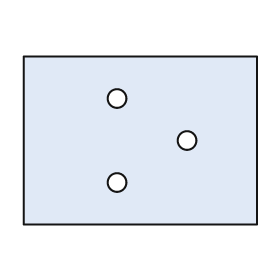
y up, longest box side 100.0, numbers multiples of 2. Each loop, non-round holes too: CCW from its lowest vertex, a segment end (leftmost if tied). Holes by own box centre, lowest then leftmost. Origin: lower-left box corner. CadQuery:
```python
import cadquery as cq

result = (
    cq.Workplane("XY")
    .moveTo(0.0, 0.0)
    .lineTo(100.0, 0.0)
    .lineTo(100.0, 72.0)
    .lineTo(0.0, 72.0)
    .close()
    .moveTo(40.0, 18.0)
    .circle(4.0)
    .moveTo(70.0, 36.0)
    .circle(4.0)
    .moveTo(40.0, 54.0)
    .circle(4.0)
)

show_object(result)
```